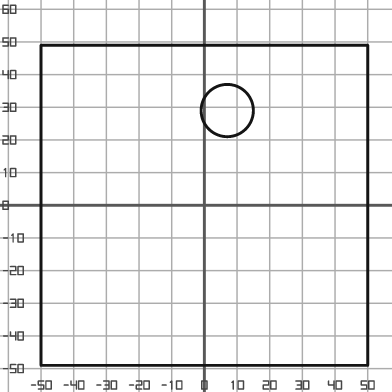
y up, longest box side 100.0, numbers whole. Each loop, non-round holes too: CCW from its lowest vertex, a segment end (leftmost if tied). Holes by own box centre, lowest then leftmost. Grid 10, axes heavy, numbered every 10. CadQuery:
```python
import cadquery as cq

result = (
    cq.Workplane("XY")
    .moveTo(-50.0, -49.0)
    .lineTo(50.0, -49.0)
    .lineTo(50.0, 49.0)
    .lineTo(-50.0, 49.0)
    .close()
    .moveTo(7.0, 29.0)
    .circle(8.0)
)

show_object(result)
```